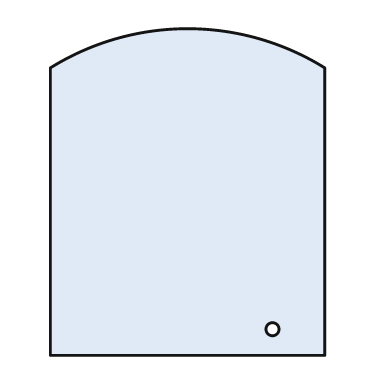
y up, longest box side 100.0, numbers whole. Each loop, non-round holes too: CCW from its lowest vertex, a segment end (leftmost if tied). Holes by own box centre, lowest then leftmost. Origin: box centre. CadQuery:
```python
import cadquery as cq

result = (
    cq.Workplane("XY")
    .moveTo(-42.0, -50.0)
    .lineTo(42.0, -50.0)
    .lineTo(42.0, 38.0)
    .threePointArc((0.0, 50.0), (-42.0, 38.0))
    .close()
    .moveTo(26.0, -42.0)
    .circle(2.0)
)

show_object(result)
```